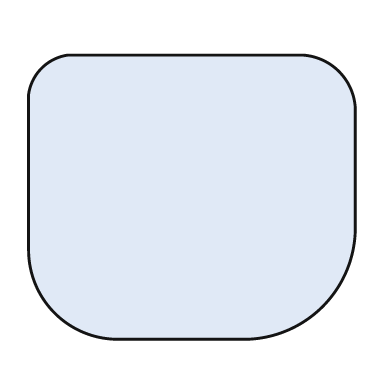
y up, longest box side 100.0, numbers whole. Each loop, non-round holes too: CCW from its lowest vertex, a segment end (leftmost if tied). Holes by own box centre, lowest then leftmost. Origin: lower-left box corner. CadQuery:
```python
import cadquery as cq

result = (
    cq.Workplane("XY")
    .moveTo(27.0, 0.0)
    .lineTo(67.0, 0.0)
    .threePointArc((90.0, 10.0), (100.0, 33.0))
    .lineTo(100.0, 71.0)
    .threePointArc((95.0, 82.0), (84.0, 87.0))
    .lineTo(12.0, 87.0)
    .threePointArc((4.0, 83.0), (0.0, 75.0))
    .lineTo(0.0, 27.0)
    .threePointArc((8.0, 8.0), (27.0, 0.0))
    .close()
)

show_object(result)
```